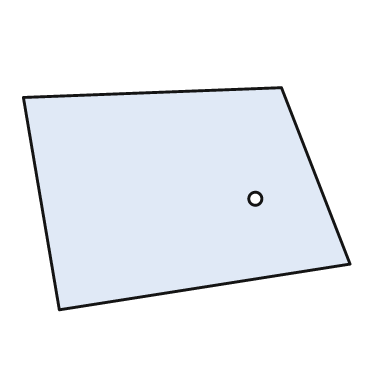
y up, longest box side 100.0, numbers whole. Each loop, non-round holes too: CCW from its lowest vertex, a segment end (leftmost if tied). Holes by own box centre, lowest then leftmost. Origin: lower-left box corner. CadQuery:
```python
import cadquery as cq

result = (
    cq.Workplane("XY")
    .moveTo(11.0, 0.0)
    .lineTo(100.0, 14.0)
    .lineTo(79.0, 68.0)
    .lineTo(0.0, 65.0)
    .close()
    .moveTo(71.0, 34.0)
    .circle(2.0)
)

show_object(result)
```